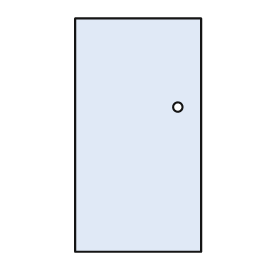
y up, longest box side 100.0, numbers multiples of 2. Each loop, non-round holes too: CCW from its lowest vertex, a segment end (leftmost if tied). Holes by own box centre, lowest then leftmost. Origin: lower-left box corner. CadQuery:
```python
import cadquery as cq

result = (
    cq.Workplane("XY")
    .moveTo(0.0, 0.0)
    .lineTo(54.0, 0.0)
    .lineTo(54.0, 100.0)
    .lineTo(0.0, 100.0)
    .close()
    .moveTo(44.0, 62.0)
    .circle(2.0)
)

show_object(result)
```